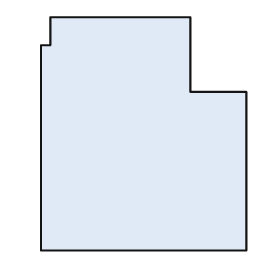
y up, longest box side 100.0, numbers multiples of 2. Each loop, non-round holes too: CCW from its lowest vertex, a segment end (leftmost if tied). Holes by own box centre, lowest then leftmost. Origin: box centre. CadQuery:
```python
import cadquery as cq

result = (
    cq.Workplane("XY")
    .moveTo(-44.0, -50.0)
    .lineTo(44.0, -50.0)
    .lineTo(44.0, 18.0)
    .lineTo(20.0, 18.0)
    .lineTo(20.0, 50.0)
    .lineTo(-40.0, 50.0)
    .lineTo(-40.0, 38.0)
    .lineTo(-44.0, 38.0)
    .close()
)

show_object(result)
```